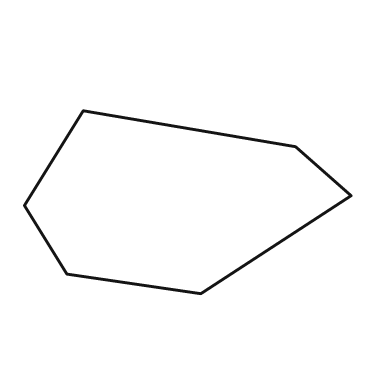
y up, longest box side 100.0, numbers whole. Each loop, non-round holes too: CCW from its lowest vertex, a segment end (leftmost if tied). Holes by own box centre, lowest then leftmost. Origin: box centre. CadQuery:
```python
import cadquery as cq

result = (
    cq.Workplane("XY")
    .moveTo(4.0, -28.0)
    .lineTo(50.0, 2.0)
    .lineTo(33.0, 17.0)
    .lineTo(-32.0, 28.0)
    .lineTo(-50.0, -1.0)
    .lineTo(-37.0, -22.0)
    .close()
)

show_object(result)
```